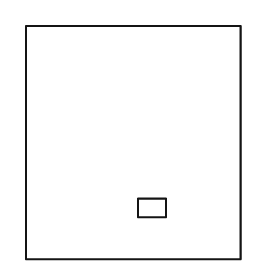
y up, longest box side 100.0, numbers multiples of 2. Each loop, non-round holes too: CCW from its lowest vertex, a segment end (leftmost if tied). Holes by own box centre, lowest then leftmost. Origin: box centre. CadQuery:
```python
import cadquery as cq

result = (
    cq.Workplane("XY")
    .moveTo(-46.0, -50.0)
    .lineTo(46.0, -50.0)
    .lineTo(46.0, 50.0)
    .lineTo(-46.0, 50.0)
    .close()
    .moveTo(2.0, -32.0)
    .lineTo(14.0, -32.0)
    .lineTo(14.0, -24.0)
    .lineTo(2.0, -24.0)
    .close()
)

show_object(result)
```